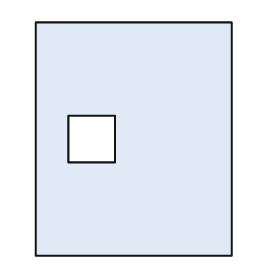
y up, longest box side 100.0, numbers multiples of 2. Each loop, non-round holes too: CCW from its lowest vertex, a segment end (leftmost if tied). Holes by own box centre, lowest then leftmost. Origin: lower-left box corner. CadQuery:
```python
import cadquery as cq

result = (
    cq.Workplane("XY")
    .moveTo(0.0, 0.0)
    .lineTo(84.0, 0.0)
    .lineTo(84.0, 100.0)
    .lineTo(0.0, 100.0)
    .close()
    .moveTo(14.0, 40.0)
    .lineTo(34.0, 40.0)
    .lineTo(34.0, 60.0)
    .lineTo(14.0, 60.0)
    .close()
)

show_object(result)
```